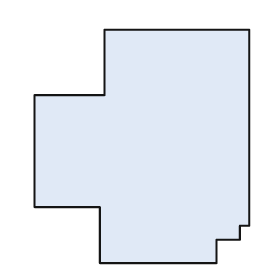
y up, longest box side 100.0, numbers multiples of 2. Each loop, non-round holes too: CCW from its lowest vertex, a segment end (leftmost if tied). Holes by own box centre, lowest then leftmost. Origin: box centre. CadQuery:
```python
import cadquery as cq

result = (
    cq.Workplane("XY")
    .moveTo(-18.0, -50.0)
    .lineTo(32.0, -50.0)
    .lineTo(32.0, -40.0)
    .lineTo(42.0, -40.0)
    .lineTo(42.0, -34.0)
    .lineTo(46.0, -34.0)
    .lineTo(46.0, 50.0)
    .lineTo(-16.0, 50.0)
    .lineTo(-16.0, 22.0)
    .lineTo(-46.0, 22.0)
    .lineTo(-46.0, -26.0)
    .lineTo(-18.0, -26.0)
    .close()
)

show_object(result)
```